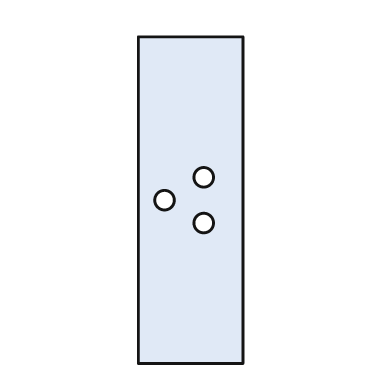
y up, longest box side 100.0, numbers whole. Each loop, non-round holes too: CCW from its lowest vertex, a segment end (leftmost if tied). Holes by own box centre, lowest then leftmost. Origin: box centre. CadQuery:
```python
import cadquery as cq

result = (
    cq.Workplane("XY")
    .moveTo(-16.0, -50.0)
    .lineTo(16.0, -50.0)
    .lineTo(16.0, 50.0)
    .lineTo(-16.0, 50.0)
    .close()
    .moveTo(4.0, -7.0)
    .circle(3.0)
    .moveTo(-8.0, 0.0)
    .circle(3.0)
    .moveTo(4.0, 7.0)
    .circle(3.0)
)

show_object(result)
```